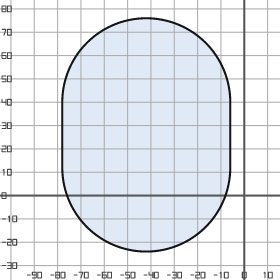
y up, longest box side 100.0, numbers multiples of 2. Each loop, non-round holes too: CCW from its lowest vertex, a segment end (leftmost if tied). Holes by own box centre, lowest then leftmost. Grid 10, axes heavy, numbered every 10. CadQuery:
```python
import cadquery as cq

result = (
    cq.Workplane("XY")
    .moveTo(-78.0, 12.0)
    .threePointArc((-42.0, -24.0), (-6.0, 12.0))
    .lineTo(-6.0, 40.0)
    .threePointArc((-42.0, 76.0), (-78.0, 40.0))
    .close()
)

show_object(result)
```